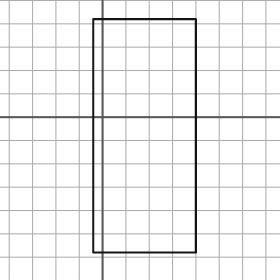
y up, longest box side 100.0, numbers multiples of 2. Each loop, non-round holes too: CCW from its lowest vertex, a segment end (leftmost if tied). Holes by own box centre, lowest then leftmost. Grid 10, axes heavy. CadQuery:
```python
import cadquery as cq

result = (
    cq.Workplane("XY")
    .moveTo(-4.0, -58.0)
    .lineTo(40.0, -58.0)
    .lineTo(40.0, 42.0)
    .lineTo(-4.0, 42.0)
    .close()
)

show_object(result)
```